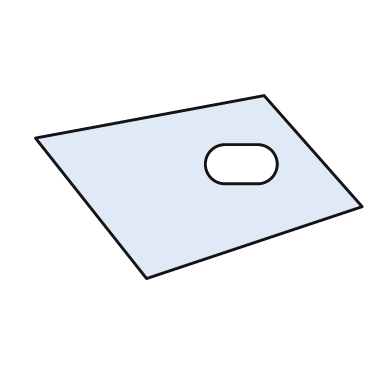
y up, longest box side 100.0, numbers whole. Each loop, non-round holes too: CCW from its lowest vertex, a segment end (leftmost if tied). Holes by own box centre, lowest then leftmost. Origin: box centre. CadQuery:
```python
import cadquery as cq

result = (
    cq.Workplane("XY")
    .moveTo(-16.0, -28.0)
    .lineTo(50.0, -6.0)
    .lineTo(20.0, 28.0)
    .lineTo(-50.0, 15.0)
    .close()
    .moveTo(8.0, 1.0)
    .lineTo(18.0, 1.0)
    .threePointArc((24.0, 7.0), (18.0, 13.0))
    .lineTo(8.0, 13.0)
    .threePointArc((2.0, 7.0), (8.0, 1.0))
    .close()
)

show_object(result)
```